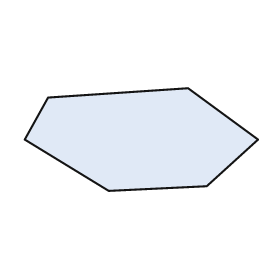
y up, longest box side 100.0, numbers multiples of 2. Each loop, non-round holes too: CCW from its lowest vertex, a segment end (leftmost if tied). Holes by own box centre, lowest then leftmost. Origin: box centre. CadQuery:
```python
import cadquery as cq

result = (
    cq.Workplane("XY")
    .moveTo(-14.0, -22.0)
    .lineTo(28.0, -20.0)
    .lineTo(50.0, 0.0)
    .lineTo(20.0, 22.0)
    .lineTo(-40.0, 18.0)
    .lineTo(-50.0, 0.0)
    .close()
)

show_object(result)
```